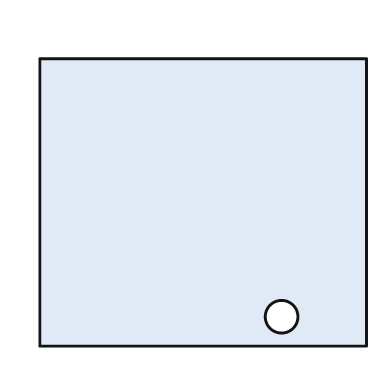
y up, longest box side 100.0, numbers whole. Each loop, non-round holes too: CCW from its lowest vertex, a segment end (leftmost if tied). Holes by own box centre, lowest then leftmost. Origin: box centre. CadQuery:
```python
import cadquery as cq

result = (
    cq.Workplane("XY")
    .moveTo(-50.0, -44.0)
    .lineTo(50.0, -44.0)
    .lineTo(50.0, 44.0)
    .lineTo(-50.0, 44.0)
    .close()
    .moveTo(24.0, -35.0)
    .circle(5.0)
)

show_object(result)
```